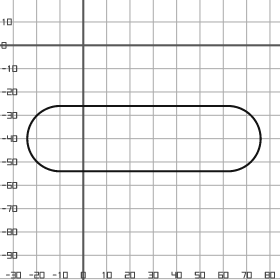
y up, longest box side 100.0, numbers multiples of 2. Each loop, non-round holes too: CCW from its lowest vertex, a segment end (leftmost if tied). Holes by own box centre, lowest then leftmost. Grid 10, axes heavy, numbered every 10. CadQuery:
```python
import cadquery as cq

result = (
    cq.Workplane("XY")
    .moveTo(-10.0, -54.0)
    .lineTo(62.0, -54.0)
    .threePointArc((76.0, -40.0), (62.0, -26.0))
    .lineTo(-10.0, -26.0)
    .threePointArc((-24.0, -40.0), (-10.0, -54.0))
    .close()
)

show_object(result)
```